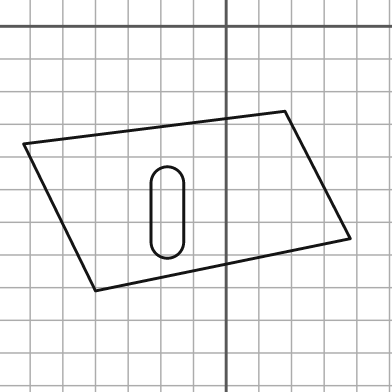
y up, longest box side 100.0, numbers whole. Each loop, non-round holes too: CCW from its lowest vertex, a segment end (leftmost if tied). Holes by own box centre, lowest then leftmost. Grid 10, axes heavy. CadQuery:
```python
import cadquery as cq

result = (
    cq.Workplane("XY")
    .moveTo(-40.0, -81.0)
    .lineTo(38.0, -65.0)
    .lineTo(18.0, -26.0)
    .lineTo(-62.0, -36.0)
    .close()
    .moveTo(-23.0, -66.0)
    .threePointArc((-18.0, -71.0), (-13.0, -66.0))
    .lineTo(-13.0, -48.0)
    .threePointArc((-18.0, -43.0), (-23.0, -48.0))
    .close()
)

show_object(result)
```